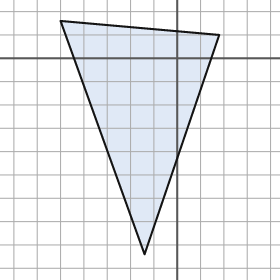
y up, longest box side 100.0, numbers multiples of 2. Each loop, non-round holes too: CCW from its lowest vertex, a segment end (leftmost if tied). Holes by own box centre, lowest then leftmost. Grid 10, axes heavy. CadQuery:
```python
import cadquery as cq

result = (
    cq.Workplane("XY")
    .moveTo(-14.0, -84.0)
    .lineTo(18.0, 10.0)
    .lineTo(-50.0, 16.0)
    .close()
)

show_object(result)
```